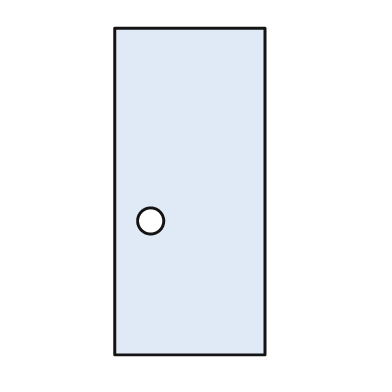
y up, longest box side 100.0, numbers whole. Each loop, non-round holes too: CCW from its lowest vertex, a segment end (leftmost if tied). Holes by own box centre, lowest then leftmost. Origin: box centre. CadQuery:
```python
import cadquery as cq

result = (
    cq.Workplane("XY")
    .moveTo(-23.0, -50.0)
    .lineTo(23.0, -50.0)
    .lineTo(23.0, 50.0)
    .lineTo(-23.0, 50.0)
    .close()
    .moveTo(-12.0, -9.0)
    .circle(4.0)
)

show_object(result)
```